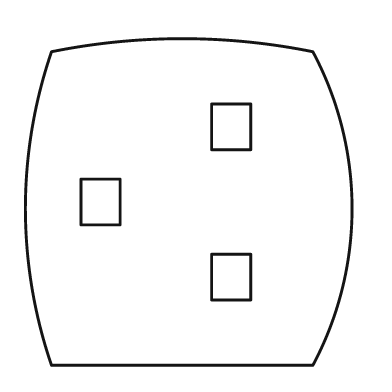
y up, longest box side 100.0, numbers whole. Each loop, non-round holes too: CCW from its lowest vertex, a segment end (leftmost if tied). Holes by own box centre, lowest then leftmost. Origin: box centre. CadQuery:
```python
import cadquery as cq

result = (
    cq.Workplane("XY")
    .moveTo(-42.0, -50.0)
    .lineTo(38.0, -50.0)
    .threePointArc((50.0, -2.0), (38.0, 46.0))
    .threePointArc((-2.0, 50.0), (-42.0, 46.0))
    .threePointArc((-50.0, -2.0), (-42.0, -50.0))
    .close()
    .moveTo(7.0, -30.0)
    .lineTo(19.0, -30.0)
    .lineTo(19.0, -16.0)
    .lineTo(7.0, -16.0)
    .close()
    .moveTo(-33.0, -7.0)
    .lineTo(-21.0, -7.0)
    .lineTo(-21.0, 7.0)
    .lineTo(-33.0, 7.0)
    .close()
    .moveTo(7.0, 16.0)
    .lineTo(19.0, 16.0)
    .lineTo(19.0, 30.0)
    .lineTo(7.0, 30.0)
    .close()
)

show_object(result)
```